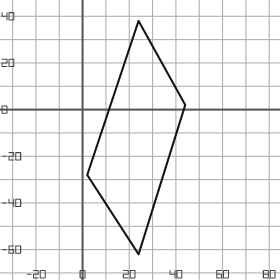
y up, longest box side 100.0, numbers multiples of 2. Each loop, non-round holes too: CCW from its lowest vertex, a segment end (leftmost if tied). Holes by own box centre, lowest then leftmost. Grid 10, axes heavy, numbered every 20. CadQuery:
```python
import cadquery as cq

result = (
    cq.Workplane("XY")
    .moveTo(24.0, -62.0)
    .lineTo(44.0, 2.0)
    .lineTo(24.0, 38.0)
    .lineTo(2.0, -28.0)
    .close()
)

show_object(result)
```